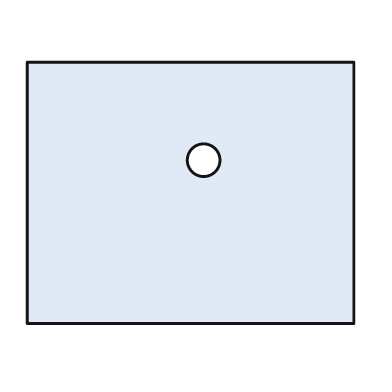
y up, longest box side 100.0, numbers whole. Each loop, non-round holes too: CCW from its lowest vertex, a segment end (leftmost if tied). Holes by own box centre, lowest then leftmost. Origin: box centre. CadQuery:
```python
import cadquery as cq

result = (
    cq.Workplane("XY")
    .moveTo(-50.0, -40.0)
    .lineTo(50.0, -40.0)
    .lineTo(50.0, 40.0)
    .lineTo(-50.0, 40.0)
    .close()
    .moveTo(4.0, 10.0)
    .circle(5.0)
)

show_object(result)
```